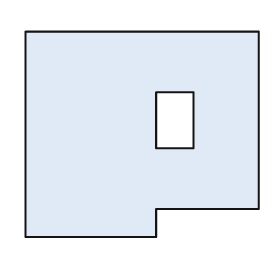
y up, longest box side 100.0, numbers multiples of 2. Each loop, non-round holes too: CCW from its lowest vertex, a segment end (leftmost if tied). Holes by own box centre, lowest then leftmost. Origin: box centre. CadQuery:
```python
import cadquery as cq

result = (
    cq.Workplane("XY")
    .moveTo(-50.0, -44.0)
    .lineTo(6.0, -44.0)
    .lineTo(6.0, -32.0)
    .lineTo(50.0, -32.0)
    .lineTo(50.0, 44.0)
    .lineTo(-50.0, 44.0)
    .close()
    .moveTo(6.0, -6.0)
    .lineTo(22.0, -6.0)
    .lineTo(22.0, 18.0)
    .lineTo(6.0, 18.0)
    .close()
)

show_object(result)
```